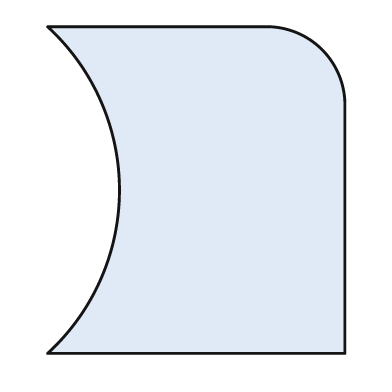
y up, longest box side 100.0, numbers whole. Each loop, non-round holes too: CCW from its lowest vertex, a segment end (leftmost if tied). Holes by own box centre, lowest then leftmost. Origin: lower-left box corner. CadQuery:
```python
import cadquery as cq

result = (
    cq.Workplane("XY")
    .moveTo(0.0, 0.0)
    .lineTo(91.0, 0.0)
    .lineTo(91.0, 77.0)
    .threePointArc((84.0, 93.0), (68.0, 100.0))
    .lineTo(0.0, 100.0)
    .threePointArc((22.0, 50.0), (0.0, 0.0))
    .close()
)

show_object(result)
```